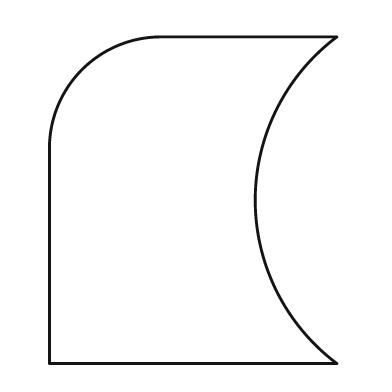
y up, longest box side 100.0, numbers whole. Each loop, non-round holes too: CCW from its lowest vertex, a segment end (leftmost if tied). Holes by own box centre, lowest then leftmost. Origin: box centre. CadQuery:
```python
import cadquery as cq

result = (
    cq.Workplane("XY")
    .moveTo(-44.0, -50.0)
    .lineTo(44.0, -50.0)
    .threePointArc((19.0, 0.0), (44.0, 50.0))
    .lineTo(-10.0, 50.0)
    .threePointArc((-34.0, 40.0), (-44.0, 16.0))
    .close()
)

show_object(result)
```